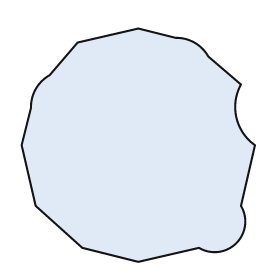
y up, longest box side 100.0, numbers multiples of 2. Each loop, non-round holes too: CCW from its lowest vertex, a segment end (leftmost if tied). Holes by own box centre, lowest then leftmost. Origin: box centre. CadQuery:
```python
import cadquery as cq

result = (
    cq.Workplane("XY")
    .moveTo(0.0, -50.0)
    .lineTo(26.0, -44.0)
    .threePointArc((42.0, -42.0), (44.0, -26.0))
    .lineTo(50.0, 0.0)
    .threePointArc((42.0, 12.0), (44.0, 26.0))
    .lineTo(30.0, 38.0)
    .threePointArc((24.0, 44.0), (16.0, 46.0))
    .lineTo(0.0, 50.0)
    .lineTo(-26.0, 44.0)
    .lineTo(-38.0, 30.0)
    .threePointArc((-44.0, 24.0), (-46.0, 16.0))
    .lineTo(-50.0, 0.0)
    .lineTo(-44.0, -26.0)
    .lineTo(-24.0, -44.0)
    .close()
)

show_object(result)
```